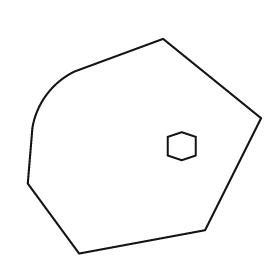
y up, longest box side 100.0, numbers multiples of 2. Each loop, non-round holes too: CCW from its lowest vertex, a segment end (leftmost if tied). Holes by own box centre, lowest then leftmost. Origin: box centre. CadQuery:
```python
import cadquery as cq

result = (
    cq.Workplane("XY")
    .moveTo(-28.0, -46.0)
    .lineTo(26.0, -36.0)
    .lineTo(50.0, 12.0)
    .lineTo(8.0, 46.0)
    .lineTo(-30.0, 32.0)
    .threePointArc((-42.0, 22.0), (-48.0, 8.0))
    .lineTo(-50.0, -16.0)
    .close()
    .moveTo(16.0, -6.0)
    .lineTo(22.0, -4.0)
    .lineTo(22.0, 4.0)
    .lineTo(16.0, 6.0)
    .lineTo(10.0, 4.0)
    .lineTo(10.0, -4.0)
    .close()
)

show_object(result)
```